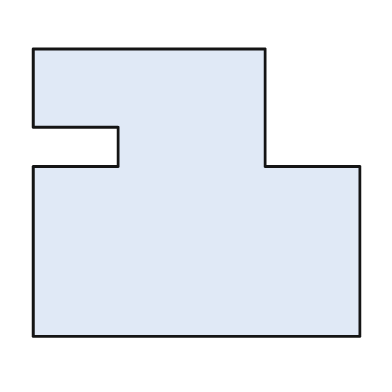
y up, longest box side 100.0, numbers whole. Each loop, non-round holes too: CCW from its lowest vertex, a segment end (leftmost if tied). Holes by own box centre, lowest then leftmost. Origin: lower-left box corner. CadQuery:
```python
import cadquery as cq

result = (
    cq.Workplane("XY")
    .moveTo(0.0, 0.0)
    .lineTo(100.0, 0.0)
    .lineTo(100.0, 52.0)
    .lineTo(71.0, 52.0)
    .lineTo(71.0, 88.0)
    .lineTo(0.0, 88.0)
    .lineTo(0.0, 64.0)
    .lineTo(26.0, 64.0)
    .lineTo(26.0, 52.0)
    .lineTo(0.0, 52.0)
    .close()
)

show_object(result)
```